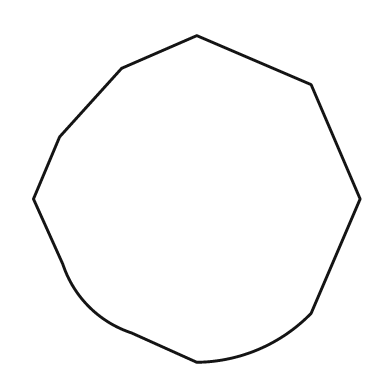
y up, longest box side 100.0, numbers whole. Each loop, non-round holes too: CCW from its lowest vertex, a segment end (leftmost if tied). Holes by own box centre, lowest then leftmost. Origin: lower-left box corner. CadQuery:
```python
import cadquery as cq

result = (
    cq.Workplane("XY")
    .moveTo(50.0, 0.0)
    .threePointArc((69.0, 4.0), (85.0, 15.0))
    .lineTo(100.0, 50.0)
    .lineTo(85.0, 85.0)
    .lineTo(50.0, 100.0)
    .lineTo(27.0, 90.0)
    .lineTo(8.0, 69.0)
    .lineTo(0.0, 50.0)
    .lineTo(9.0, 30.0)
    .threePointArc((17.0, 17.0), (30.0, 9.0))
    .close()
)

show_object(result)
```